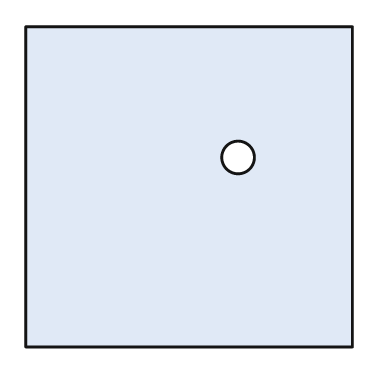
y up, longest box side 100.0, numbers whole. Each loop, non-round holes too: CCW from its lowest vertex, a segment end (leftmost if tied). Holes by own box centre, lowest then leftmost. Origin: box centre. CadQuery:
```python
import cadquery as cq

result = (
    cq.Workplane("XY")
    .moveTo(-50.0, -49.0)
    .lineTo(50.0, -49.0)
    .lineTo(50.0, 49.0)
    .lineTo(-50.0, 49.0)
    .close()
    .moveTo(15.0, 9.0)
    .circle(5.0)
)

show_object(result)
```